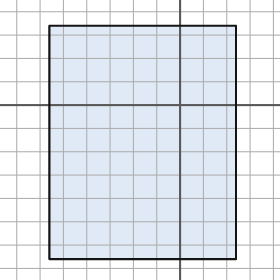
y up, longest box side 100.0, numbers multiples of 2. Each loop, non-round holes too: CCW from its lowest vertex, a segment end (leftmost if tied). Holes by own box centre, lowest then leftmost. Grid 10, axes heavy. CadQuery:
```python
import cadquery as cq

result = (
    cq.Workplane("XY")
    .moveTo(-56.0, -66.0)
    .lineTo(24.0, -66.0)
    .lineTo(24.0, 34.0)
    .lineTo(-56.0, 34.0)
    .close()
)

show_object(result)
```